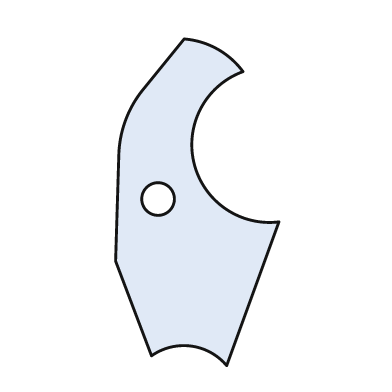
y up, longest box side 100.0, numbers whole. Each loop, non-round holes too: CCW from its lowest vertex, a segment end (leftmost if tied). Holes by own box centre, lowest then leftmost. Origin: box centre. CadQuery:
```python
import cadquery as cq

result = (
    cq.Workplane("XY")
    .moveTo(9.0, -50.0)
    .lineTo(25.0, -6.0)
    .threePointArc((-1.0, 12.0), (14.0, 40.0))
    .threePointArc((6.0, 47.0), (-4.0, 50.0))
    .lineTo(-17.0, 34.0)
    .threePointArc((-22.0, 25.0), (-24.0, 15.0))
    .lineTo(-25.0, -18.0)
    .lineTo(-14.0, -47.0)
    .threePointArc((-2.0, -44.0), (9.0, -50.0))
    .close()
    .moveTo(-12.0, 1.0)
    .circle(5.0)
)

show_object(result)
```